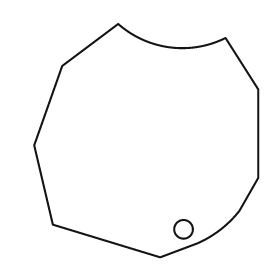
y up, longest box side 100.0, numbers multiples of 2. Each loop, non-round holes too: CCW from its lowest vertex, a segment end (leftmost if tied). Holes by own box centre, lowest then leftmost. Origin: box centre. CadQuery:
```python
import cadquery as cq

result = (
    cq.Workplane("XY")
    .moveTo(6.0, -50.0)
    .lineTo(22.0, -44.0)
    .threePointArc((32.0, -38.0), (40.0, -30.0))
    .lineTo(48.0, -16.0)
    .lineTo(48.0, 22.0)
    .lineTo(34.0, 44.0)
    .threePointArc((10.0, 40.0), (-12.0, 50.0))
    .lineTo(-36.0, 32.0)
    .lineTo(-48.0, -2.0)
    .lineTo(-40.0, -36.0)
    .close()
    .moveTo(16.0, -38.0)
    .circle(4.0)
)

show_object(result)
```